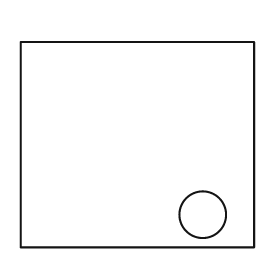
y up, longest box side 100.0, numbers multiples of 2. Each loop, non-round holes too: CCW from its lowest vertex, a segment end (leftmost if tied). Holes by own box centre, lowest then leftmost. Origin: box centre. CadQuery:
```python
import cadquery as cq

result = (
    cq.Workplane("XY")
    .moveTo(-50.0, -44.0)
    .lineTo(50.0, -44.0)
    .lineTo(50.0, 44.0)
    .lineTo(-50.0, 44.0)
    .close()
    .moveTo(28.0, -30.0)
    .circle(10.0)
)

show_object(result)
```